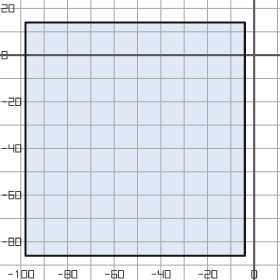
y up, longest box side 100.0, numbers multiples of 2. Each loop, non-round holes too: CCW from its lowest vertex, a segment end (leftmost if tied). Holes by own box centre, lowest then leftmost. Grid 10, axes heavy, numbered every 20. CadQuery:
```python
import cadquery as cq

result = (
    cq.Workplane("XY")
    .moveTo(-98.0, -86.0)
    .lineTo(-4.0, -86.0)
    .lineTo(-4.0, 14.0)
    .lineTo(-98.0, 14.0)
    .close()
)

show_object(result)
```